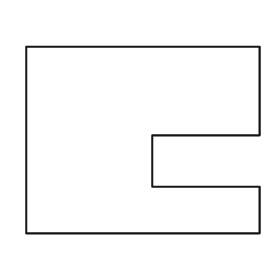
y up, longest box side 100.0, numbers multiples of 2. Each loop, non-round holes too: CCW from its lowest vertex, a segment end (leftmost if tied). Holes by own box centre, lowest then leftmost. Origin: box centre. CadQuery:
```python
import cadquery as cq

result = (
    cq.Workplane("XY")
    .moveTo(-50.0, -40.0)
    .lineTo(50.0, -40.0)
    .lineTo(50.0, -20.0)
    .lineTo(4.0, -20.0)
    .lineTo(4.0, 2.0)
    .lineTo(50.0, 2.0)
    .lineTo(50.0, 40.0)
    .lineTo(-50.0, 40.0)
    .close()
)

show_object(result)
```